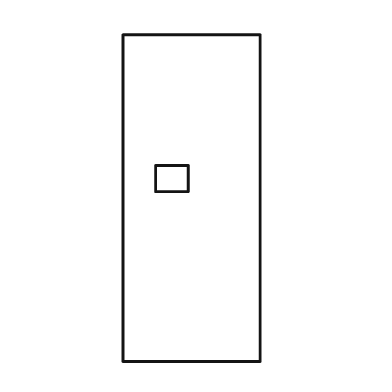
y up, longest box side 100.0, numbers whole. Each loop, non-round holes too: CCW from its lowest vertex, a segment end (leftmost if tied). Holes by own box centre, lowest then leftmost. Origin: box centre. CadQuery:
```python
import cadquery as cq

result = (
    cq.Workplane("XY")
    .moveTo(-21.0, -50.0)
    .lineTo(21.0, -50.0)
    .lineTo(21.0, 50.0)
    .lineTo(-21.0, 50.0)
    .close()
    .moveTo(-11.0, 2.0)
    .lineTo(-1.0, 2.0)
    .lineTo(-1.0, 10.0)
    .lineTo(-11.0, 10.0)
    .close()
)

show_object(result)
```